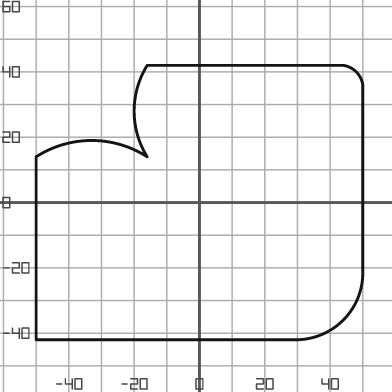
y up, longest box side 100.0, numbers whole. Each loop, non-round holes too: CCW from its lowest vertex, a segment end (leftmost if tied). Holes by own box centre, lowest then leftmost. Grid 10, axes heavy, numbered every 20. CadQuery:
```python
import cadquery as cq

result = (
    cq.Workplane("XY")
    .moveTo(-50.0, -42.0)
    .lineTo(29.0, -42.0)
    .threePointArc((44.0, -36.0), (50.0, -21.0))
    .lineTo(50.0, 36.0)
    .threePointArc((48.0, 40.0), (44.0, 42.0))
    .lineTo(-16.0, 42.0)
    .threePointArc((-20.0, 28.0), (-16.0, 14.0))
    .threePointArc((-33.0, 19.0), (-50.0, 14.0))
    .close()
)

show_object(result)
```